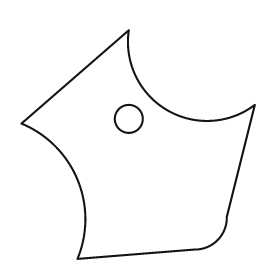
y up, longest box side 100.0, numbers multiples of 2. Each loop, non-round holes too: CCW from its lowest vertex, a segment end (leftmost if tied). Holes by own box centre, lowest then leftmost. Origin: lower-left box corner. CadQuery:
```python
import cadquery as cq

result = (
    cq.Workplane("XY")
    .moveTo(24.0, 0.0)
    .lineTo(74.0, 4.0)
    .threePointArc((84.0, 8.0), (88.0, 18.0))
    .lineTo(100.0, 66.0)
    .threePointArc((62.0, 64.0), (46.0, 98.0))
    .lineTo(0.0, 58.0)
    .threePointArc((24.0, 34.0), (24.0, 0.0))
    .close()
    .moveTo(46.0, 60.0)
    .circle(6.0)
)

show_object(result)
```